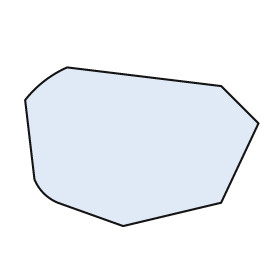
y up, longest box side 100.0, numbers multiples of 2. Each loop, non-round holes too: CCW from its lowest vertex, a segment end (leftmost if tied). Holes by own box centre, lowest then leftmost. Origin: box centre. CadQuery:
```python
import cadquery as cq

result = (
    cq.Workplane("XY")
    .moveTo(-8.0, -34.0)
    .lineTo(34.0, -24.0)
    .lineTo(50.0, 10.0)
    .lineTo(34.0, 26.0)
    .lineTo(-32.0, 34.0)
    .threePointArc((-42.0, 28.0), (-50.0, 20.0))
    .lineTo(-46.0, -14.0)
    .threePointArc((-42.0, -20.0), (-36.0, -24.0))
    .close()
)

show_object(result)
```